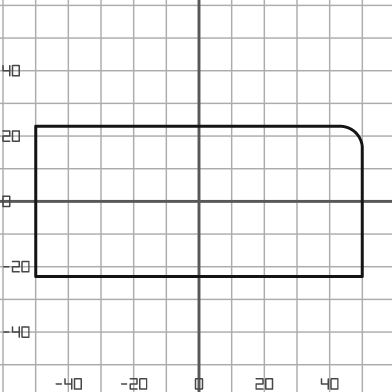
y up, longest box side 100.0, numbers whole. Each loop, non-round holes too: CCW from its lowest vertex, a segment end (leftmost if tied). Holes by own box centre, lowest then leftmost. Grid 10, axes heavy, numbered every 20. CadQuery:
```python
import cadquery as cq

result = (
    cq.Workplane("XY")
    .moveTo(-50.0, -23.0)
    .lineTo(50.0, -23.0)
    .lineTo(50.0, 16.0)
    .threePointArc((48.0, 21.0), (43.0, 23.0))
    .lineTo(-50.0, 23.0)
    .close()
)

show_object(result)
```